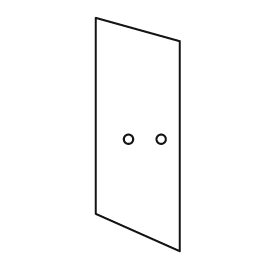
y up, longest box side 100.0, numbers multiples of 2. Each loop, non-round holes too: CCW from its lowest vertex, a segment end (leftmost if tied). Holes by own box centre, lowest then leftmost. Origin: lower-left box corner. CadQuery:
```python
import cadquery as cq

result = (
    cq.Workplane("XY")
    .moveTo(36.0, 0.0)
    .lineTo(36.0, 90.0)
    .lineTo(0.0, 100.0)
    .lineTo(0.0, 16.0)
    .close()
    .moveTo(14.0, 48.0)
    .circle(2.0)
    .moveTo(28.0, 48.0)
    .circle(2.0)
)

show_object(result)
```